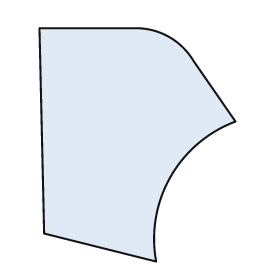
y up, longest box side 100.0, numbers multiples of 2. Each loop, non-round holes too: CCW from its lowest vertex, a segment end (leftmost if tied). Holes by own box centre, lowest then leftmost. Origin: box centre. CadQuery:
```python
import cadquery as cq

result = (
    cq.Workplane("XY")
    .moveTo(8.0, -50.0)
    .threePointArc((14.0, -14.0), (42.0, 10.0))
    .lineTo(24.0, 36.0)
    .threePointArc((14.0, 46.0), (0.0, 50.0))
    .lineTo(-42.0, 50.0)
    .lineTo(-40.0, -38.0)
    .close()
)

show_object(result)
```